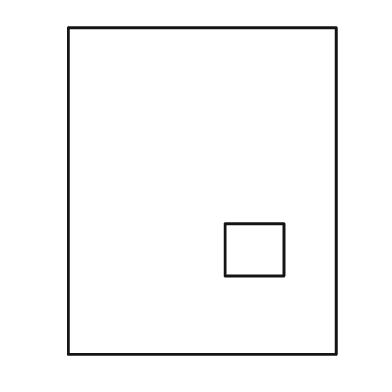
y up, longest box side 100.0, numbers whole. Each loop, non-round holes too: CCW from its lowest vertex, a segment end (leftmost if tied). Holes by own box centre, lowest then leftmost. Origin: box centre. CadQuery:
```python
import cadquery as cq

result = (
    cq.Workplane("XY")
    .moveTo(-41.0, -50.0)
    .lineTo(41.0, -50.0)
    .lineTo(41.0, 50.0)
    .lineTo(-41.0, 50.0)
    .close()
    .moveTo(7.0, -26.0)
    .lineTo(25.0, -26.0)
    .lineTo(25.0, -10.0)
    .lineTo(7.0, -10.0)
    .close()
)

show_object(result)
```